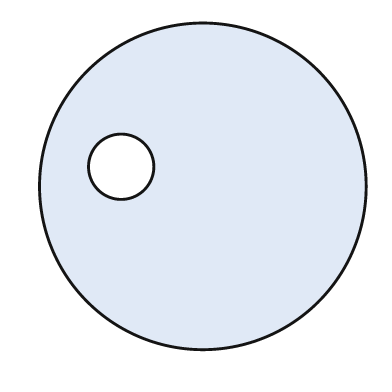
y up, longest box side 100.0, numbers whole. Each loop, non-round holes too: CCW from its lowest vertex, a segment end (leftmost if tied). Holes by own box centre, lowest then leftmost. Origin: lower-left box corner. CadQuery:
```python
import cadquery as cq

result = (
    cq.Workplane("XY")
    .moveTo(50.0, 50.0)
    .circle(50.0)
    .moveTo(25.0, 56.0)
    .circle(10.0)
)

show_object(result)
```